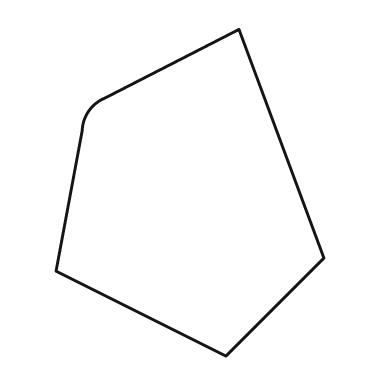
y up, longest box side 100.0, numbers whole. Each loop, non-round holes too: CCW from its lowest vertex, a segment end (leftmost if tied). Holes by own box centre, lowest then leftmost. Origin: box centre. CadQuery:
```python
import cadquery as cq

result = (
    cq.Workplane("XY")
    .moveTo(11.0, -50.0)
    .lineTo(41.0, -20.0)
    .lineTo(15.0, 50.0)
    .lineTo(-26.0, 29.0)
    .threePointArc((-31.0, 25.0), (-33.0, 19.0))
    .lineTo(-41.0, -24.0)
    .close()
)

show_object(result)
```